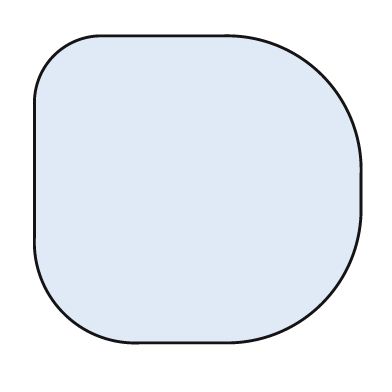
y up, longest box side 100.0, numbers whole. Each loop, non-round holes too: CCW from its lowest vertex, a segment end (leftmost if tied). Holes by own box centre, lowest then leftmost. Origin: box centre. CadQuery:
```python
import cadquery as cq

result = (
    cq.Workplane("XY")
    .moveTo(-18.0, -47.0)
    .lineTo(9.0, -47.0)
    .threePointArc((38.0, -35.0), (50.0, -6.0))
    .lineTo(50.0, 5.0)
    .threePointArc((38.0, 35.0), (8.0, 47.0))
    .lineTo(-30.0, 47.0)
    .threePointArc((-44.0, 41.0), (-50.0, 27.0))
    .lineTo(-50.0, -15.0)
    .threePointArc((-41.0, -38.0), (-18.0, -47.0))
    .close()
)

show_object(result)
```